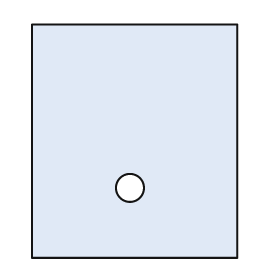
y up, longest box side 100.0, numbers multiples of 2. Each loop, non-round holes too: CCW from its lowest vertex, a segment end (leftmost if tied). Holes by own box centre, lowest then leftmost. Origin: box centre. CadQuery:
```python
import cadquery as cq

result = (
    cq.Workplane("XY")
    .moveTo(-44.0, -50.0)
    .lineTo(44.0, -50.0)
    .lineTo(44.0, 50.0)
    .lineTo(-44.0, 50.0)
    .close()
    .moveTo(-2.0, -20.0)
    .circle(6.0)
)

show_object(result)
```